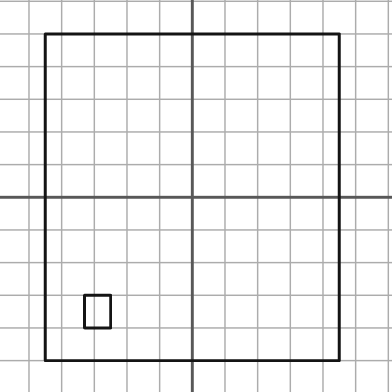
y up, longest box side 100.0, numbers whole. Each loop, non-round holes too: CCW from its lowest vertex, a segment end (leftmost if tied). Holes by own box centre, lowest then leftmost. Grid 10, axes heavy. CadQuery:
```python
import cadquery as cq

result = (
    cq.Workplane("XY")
    .moveTo(-45.0, -50.0)
    .lineTo(45.0, -50.0)
    .lineTo(45.0, 50.0)
    .lineTo(-45.0, 50.0)
    .close()
    .moveTo(-33.0, -40.0)
    .lineTo(-25.0, -40.0)
    .lineTo(-25.0, -30.0)
    .lineTo(-33.0, -30.0)
    .close()
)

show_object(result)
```